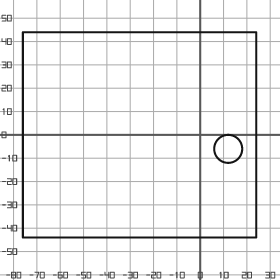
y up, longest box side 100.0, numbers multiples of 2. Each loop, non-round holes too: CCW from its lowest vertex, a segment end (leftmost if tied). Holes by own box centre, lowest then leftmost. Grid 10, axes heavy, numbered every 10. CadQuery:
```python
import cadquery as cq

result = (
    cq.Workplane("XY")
    .moveTo(-76.0, -44.0)
    .lineTo(24.0, -44.0)
    .lineTo(24.0, 44.0)
    .lineTo(-76.0, 44.0)
    .close()
    .moveTo(12.0, -6.0)
    .circle(6.0)
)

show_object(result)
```